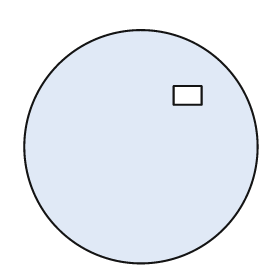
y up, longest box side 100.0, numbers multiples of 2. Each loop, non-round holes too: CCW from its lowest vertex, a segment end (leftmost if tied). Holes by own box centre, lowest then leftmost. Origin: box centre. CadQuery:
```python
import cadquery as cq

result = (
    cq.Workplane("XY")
    .moveTo(0.0, 0.0)
    .circle(50.0)
    .moveTo(14.0, 18.0)
    .lineTo(26.0, 18.0)
    .lineTo(26.0, 26.0)
    .lineTo(14.0, 26.0)
    .close()
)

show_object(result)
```